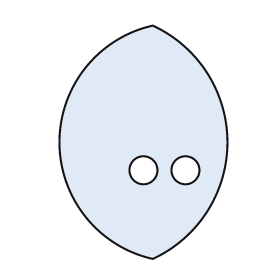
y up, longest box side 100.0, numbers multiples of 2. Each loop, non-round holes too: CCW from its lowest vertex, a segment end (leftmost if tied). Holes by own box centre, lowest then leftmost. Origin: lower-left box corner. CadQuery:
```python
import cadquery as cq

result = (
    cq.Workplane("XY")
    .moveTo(40.0, 0.0)
    .threePointArc((72.0, 50.0), (40.0, 100.0))
    .threePointArc((0.0, 50.0), (40.0, 0.0))
    .close()
    .moveTo(36.0, 38.0)
    .circle(6.0)
    .moveTo(54.0, 38.0)
    .circle(6.0)
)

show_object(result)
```